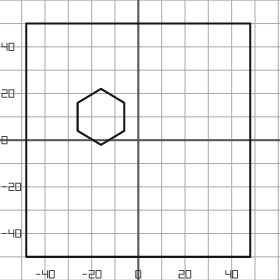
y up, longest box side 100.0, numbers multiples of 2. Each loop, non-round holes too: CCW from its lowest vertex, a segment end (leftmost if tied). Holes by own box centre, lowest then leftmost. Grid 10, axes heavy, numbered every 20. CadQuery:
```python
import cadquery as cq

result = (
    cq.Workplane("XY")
    .moveTo(-48.0, -50.0)
    .lineTo(48.0, -50.0)
    .lineTo(48.0, 50.0)
    .lineTo(-48.0, 50.0)
    .close()
    .moveTo(-16.0, -2.0)
    .lineTo(-6.0, 4.0)
    .lineTo(-6.0, 16.0)
    .lineTo(-16.0, 22.0)
    .lineTo(-26.0, 16.0)
    .lineTo(-26.0, 4.0)
    .close()
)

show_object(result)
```